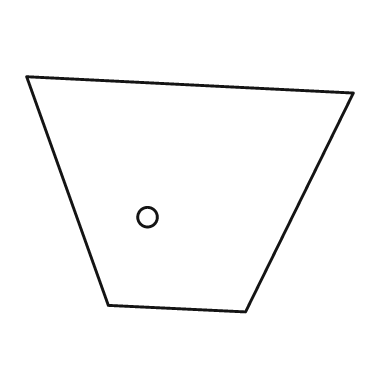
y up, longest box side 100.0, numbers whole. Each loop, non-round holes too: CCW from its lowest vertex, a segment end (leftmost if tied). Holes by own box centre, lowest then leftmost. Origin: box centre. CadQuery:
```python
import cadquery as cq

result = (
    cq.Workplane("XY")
    .moveTo(17.0, -36.0)
    .lineTo(50.0, 31.0)
    .lineTo(-50.0, 36.0)
    .lineTo(-25.0, -34.0)
    .close()
    .moveTo(-13.0, -7.0)
    .circle(3.0)
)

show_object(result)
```